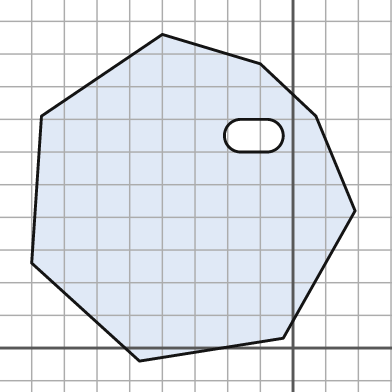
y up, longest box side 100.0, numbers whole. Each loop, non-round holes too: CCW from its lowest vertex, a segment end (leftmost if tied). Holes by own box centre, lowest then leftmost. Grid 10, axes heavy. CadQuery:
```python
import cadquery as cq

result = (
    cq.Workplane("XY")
    .moveTo(-47.0, -4.0)
    .lineTo(-3.0, 3.0)
    .lineTo(19.0, 42.0)
    .lineTo(7.0, 71.0)
    .lineTo(-10.0, 87.0)
    .lineTo(-40.0, 96.0)
    .lineTo(-77.0, 71.0)
    .lineTo(-80.0, 26.0)
    .close()
    .moveTo(-16.0, 60.0)
    .lineTo(-8.0, 60.0)
    .threePointArc((-3.0, 65.0), (-8.0, 70.0))
    .lineTo(-16.0, 70.0)
    .threePointArc((-21.0, 65.0), (-16.0, 60.0))
    .close()
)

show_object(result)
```